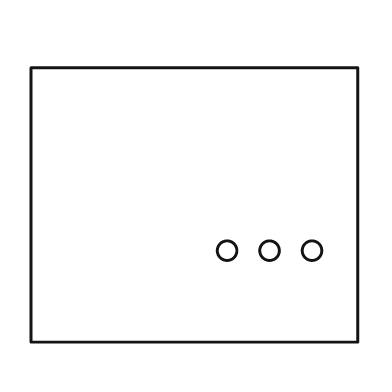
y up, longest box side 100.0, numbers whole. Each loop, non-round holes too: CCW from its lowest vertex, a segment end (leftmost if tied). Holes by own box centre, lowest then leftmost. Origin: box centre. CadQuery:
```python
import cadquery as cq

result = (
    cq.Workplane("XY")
    .moveTo(-50.0, -42.0)
    .lineTo(50.0, -42.0)
    .lineTo(50.0, 42.0)
    .lineTo(-50.0, 42.0)
    .close()
    .moveTo(10.0, -14.0)
    .circle(3.0)
    .moveTo(23.0, -14.0)
    .circle(3.0)
    .moveTo(36.0, -14.0)
    .circle(3.0)
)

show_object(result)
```